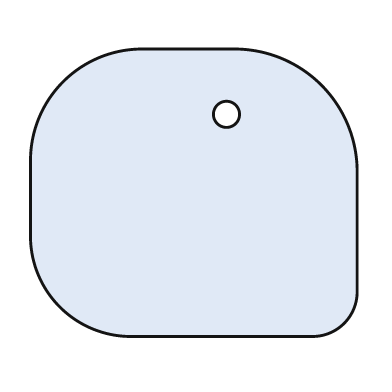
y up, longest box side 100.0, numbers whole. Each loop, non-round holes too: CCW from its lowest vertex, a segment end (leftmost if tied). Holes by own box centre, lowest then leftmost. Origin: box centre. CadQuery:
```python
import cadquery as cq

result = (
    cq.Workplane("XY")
    .moveTo(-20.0, -44.0)
    .lineTo(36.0, -44.0)
    .threePointArc((46.0, -40.0), (50.0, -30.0))
    .lineTo(50.0, 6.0)
    .threePointArc((39.0, 33.0), (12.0, 44.0))
    .lineTo(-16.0, 44.0)
    .threePointArc((-40.0, 34.0), (-50.0, 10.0))
    .lineTo(-50.0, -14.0)
    .threePointArc((-41.0, -35.0), (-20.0, -44.0))
    .close()
    .moveTo(10.0, 24.0)
    .circle(4.0)
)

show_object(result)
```